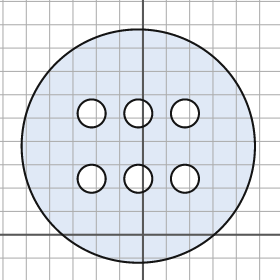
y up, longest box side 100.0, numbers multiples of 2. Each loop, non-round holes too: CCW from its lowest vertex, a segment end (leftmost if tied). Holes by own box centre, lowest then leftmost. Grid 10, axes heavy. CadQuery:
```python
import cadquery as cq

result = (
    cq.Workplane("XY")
    .moveTo(-2.0, 38.0)
    .circle(50.0)
    .moveTo(-22.0, 24.0)
    .circle(6.0)
    .moveTo(-2.0, 24.0)
    .circle(6.0)
    .moveTo(18.0, 24.0)
    .circle(6.0)
    .moveTo(-22.0, 52.0)
    .circle(6.0)
    .moveTo(-2.0, 52.0)
    .circle(6.0)
    .moveTo(18.0, 52.0)
    .circle(6.0)
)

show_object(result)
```